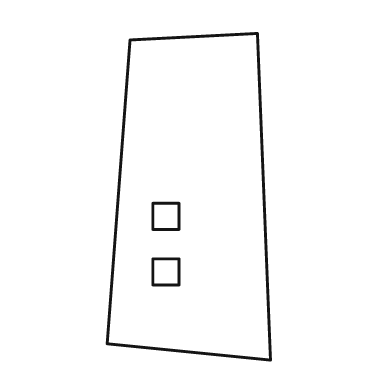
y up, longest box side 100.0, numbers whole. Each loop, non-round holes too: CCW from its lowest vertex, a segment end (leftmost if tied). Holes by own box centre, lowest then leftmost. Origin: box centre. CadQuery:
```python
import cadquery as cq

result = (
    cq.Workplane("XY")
    .moveTo(25.0, -50.0)
    .lineTo(21.0, 50.0)
    .lineTo(-18.0, 48.0)
    .lineTo(-25.0, -45.0)
    .close()
    .moveTo(-11.0, -27.0)
    .lineTo(-3.0, -27.0)
    .lineTo(-3.0, -19.0)
    .lineTo(-11.0, -19.0)
    .close()
    .moveTo(-11.0, -10.0)
    .lineTo(-3.0, -10.0)
    .lineTo(-3.0, -2.0)
    .lineTo(-11.0, -2.0)
    .close()
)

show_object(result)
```